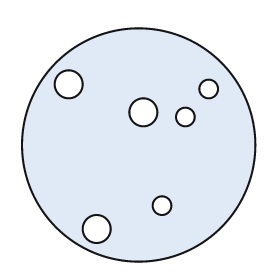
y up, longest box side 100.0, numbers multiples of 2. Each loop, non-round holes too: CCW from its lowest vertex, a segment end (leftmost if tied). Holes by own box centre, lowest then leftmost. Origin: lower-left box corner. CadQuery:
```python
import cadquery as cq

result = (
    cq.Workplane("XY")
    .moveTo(50.0, 50.0)
    .circle(50.0)
    .moveTo(32.0, 14.0)
    .circle(6.0)
    .moveTo(60.0, 24.0)
    .circle(4.0)
    .moveTo(70.0, 62.0)
    .circle(4.0)
    .moveTo(52.0, 64.0)
    .circle(6.0)
    .moveTo(80.0, 74.0)
    .circle(4.0)
    .moveTo(20.0, 76.0)
    .circle(6.0)
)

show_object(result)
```